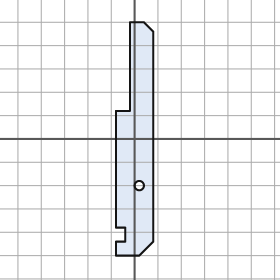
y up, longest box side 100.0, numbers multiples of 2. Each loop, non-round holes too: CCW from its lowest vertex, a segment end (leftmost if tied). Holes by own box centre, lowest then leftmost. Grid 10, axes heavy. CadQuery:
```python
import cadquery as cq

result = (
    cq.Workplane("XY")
    .moveTo(-8.0, -50.0)
    .lineTo(2.0, -50.0)
    .lineTo(8.0, -44.0)
    .lineTo(8.0, 46.0)
    .lineTo(4.0, 50.0)
    .lineTo(-2.0, 50.0)
    .lineTo(-2.0, 12.0)
    .lineTo(-8.0, 12.0)
    .lineTo(-8.0, -38.0)
    .lineTo(-4.0, -38.0)
    .lineTo(-4.0, -44.0)
    .lineTo(-8.0, -44.0)
    .close()
    .moveTo(2.0, -20.0)
    .circle(2.0)
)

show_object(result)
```